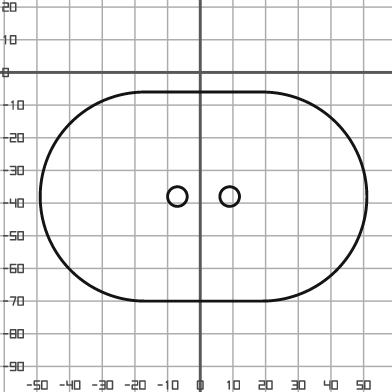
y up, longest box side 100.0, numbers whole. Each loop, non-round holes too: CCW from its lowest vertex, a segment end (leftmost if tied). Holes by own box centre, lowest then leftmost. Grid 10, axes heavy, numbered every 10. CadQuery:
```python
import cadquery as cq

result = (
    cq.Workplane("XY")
    .moveTo(-17.0, -70.0)
    .lineTo(19.0, -70.0)
    .threePointArc((51.0, -38.0), (19.0, -6.0))
    .lineTo(-17.0, -6.0)
    .threePointArc((-49.0, -38.0), (-17.0, -70.0))
    .close()
    .moveTo(-7.0, -38.0)
    .circle(3.0)
    .moveTo(9.0, -38.0)
    .circle(3.0)
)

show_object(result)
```